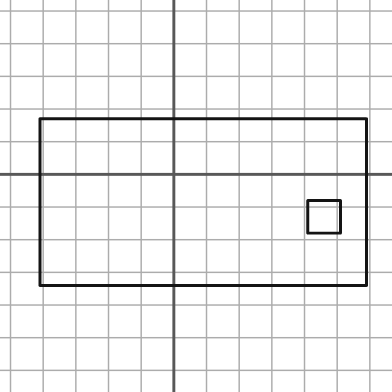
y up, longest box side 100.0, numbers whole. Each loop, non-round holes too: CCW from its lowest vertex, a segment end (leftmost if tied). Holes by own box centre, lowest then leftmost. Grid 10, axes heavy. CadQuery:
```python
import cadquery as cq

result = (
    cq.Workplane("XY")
    .moveTo(-41.0, -34.0)
    .lineTo(59.0, -34.0)
    .lineTo(59.0, 17.0)
    .lineTo(-41.0, 17.0)
    .close()
    .moveTo(41.0, -18.0)
    .lineTo(51.0, -18.0)
    .lineTo(51.0, -8.0)
    .lineTo(41.0, -8.0)
    .close()
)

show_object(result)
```